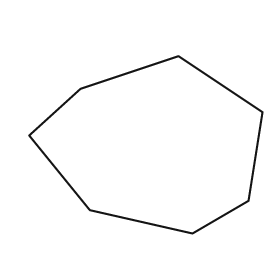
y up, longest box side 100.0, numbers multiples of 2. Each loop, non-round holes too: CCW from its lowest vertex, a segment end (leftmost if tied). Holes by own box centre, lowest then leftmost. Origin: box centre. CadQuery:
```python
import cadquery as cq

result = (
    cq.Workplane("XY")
    .moveTo(20.0, -38.0)
    .lineTo(44.0, -24.0)
    .lineTo(50.0, 14.0)
    .lineTo(14.0, 38.0)
    .lineTo(-28.0, 24.0)
    .lineTo(-50.0, 4.0)
    .lineTo(-24.0, -28.0)
    .close()
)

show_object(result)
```